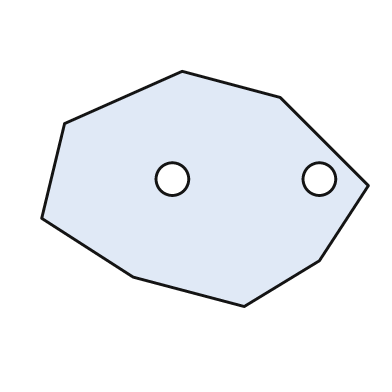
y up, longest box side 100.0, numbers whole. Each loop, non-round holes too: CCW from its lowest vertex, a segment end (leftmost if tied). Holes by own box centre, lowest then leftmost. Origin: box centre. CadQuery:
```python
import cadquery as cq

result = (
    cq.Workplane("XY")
    .moveTo(12.0, -36.0)
    .lineTo(35.0, -22.0)
    .lineTo(50.0, 1.0)
    .lineTo(23.0, 28.0)
    .lineTo(-7.0, 36.0)
    .lineTo(-43.0, 20.0)
    .lineTo(-50.0, -9.0)
    .lineTo(-22.0, -27.0)
    .close()
    .moveTo(-10.0, 3.0)
    .circle(5.0)
    .moveTo(35.0, 3.0)
    .circle(5.0)
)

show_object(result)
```